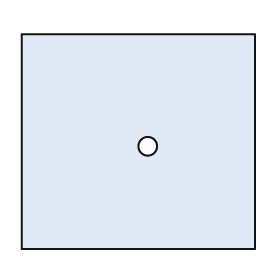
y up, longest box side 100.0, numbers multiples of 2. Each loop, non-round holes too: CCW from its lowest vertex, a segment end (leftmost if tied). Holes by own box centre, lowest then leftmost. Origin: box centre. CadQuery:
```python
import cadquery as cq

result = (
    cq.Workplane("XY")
    .moveTo(-50.0, -46.0)
    .lineTo(50.0, -46.0)
    .lineTo(50.0, 46.0)
    .lineTo(-50.0, 46.0)
    .close()
    .moveTo(4.0, -2.0)
    .circle(4.0)
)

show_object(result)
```